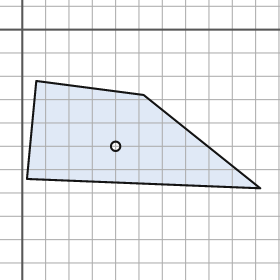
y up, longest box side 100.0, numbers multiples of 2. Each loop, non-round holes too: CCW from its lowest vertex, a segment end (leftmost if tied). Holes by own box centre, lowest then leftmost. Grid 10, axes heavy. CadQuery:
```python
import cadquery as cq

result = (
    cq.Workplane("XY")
    .moveTo(102.0, -68.0)
    .lineTo(52.0, -28.0)
    .lineTo(6.0, -22.0)
    .lineTo(2.0, -64.0)
    .close()
    .moveTo(40.0, -50.0)
    .circle(2.0)
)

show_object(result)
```